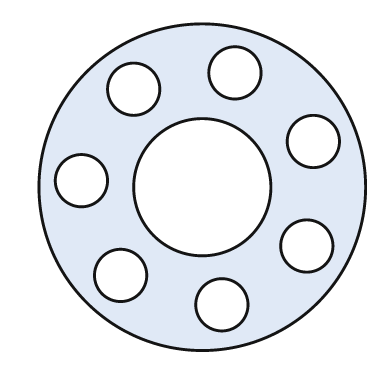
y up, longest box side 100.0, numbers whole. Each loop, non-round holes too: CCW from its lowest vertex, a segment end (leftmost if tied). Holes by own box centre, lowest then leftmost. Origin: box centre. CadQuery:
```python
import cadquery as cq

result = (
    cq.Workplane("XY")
    .moveTo(0.0, 0.0)
    .circle(50.0)
    .moveTo(6.0, -36.0)
    .circle(8.0)
    .moveTo(-25.0, -27.0)
    .circle(8.0)
    .moveTo(32.0, -18.0)
    .circle(8.0)
    .moveTo(0.0, 0.0)
    .circle(21.0)
    .moveTo(-37.0, 2.0)
    .circle(8.0)
    .moveTo(34.0, 14.0)
    .circle(8.0)
    .moveTo(-21.0, 30.0)
    .circle(8.0)
    .moveTo(10.0, 35.0)
    .circle(8.0)
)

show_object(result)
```